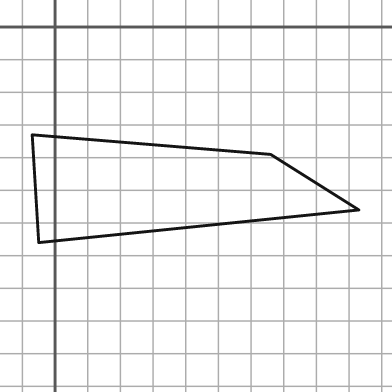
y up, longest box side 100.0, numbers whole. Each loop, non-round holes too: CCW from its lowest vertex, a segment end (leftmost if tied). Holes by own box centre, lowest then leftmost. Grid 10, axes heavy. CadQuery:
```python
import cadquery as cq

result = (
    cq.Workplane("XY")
    .moveTo(-5.0, -66.0)
    .lineTo(93.0, -56.0)
    .lineTo(66.0, -39.0)
    .lineTo(-7.0, -33.0)
    .close()
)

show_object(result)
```